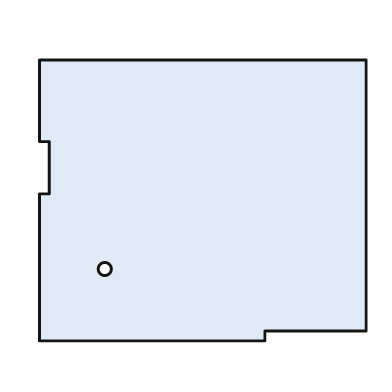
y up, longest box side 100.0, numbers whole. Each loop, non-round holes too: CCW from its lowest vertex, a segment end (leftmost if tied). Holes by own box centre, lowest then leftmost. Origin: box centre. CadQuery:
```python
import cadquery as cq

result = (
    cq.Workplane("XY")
    .moveTo(-50.0, -43.0)
    .lineTo(19.0, -43.0)
    .lineTo(19.0, -40.0)
    .lineTo(50.0, -40.0)
    .lineTo(50.0, 43.0)
    .lineTo(-50.0, 43.0)
    .lineTo(-50.0, 18.0)
    .lineTo(-47.0, 18.0)
    .lineTo(-47.0, 2.0)
    .lineTo(-50.0, 2.0)
    .close()
    .moveTo(-30.0, -21.0)
    .circle(2.0)
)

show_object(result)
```